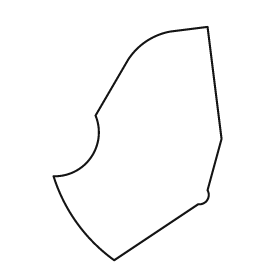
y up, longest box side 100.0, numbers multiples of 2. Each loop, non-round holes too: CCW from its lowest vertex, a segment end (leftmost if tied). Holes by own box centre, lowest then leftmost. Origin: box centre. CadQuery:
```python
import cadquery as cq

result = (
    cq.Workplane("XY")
    .moveTo(-10.0, -50.0)
    .lineTo(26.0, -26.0)
    .threePointArc((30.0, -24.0), (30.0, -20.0))
    .lineTo(36.0, 2.0)
    .lineTo(30.0, 50.0)
    .lineTo(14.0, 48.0)
    .threePointArc((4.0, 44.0), (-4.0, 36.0))
    .lineTo(-18.0, 12.0)
    .threePointArc((-20.0, -6.0), (-36.0, -14.0))
    .threePointArc((-26.0, -34.0), (-10.0, -50.0))
    .close()
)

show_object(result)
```